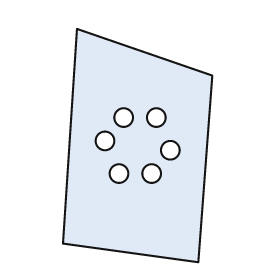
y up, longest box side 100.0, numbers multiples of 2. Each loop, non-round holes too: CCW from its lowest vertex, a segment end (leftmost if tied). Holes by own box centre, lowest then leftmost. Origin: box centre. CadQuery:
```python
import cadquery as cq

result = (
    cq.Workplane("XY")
    .moveTo(26.0, -50.0)
    .lineTo(32.0, 30.0)
    .lineTo(-26.0, 50.0)
    .lineTo(-32.0, -42.0)
    .close()
    .moveTo(-8.0, -12.0)
    .circle(4.0)
    .moveTo(6.0, -12.0)
    .circle(4.0)
    .moveTo(14.0, -2.0)
    .circle(4.0)
    .moveTo(-14.0, 2.0)
    .circle(4.0)
    .moveTo(-6.0, 12.0)
    .circle(4.0)
    .moveTo(8.0, 12.0)
    .circle(4.0)
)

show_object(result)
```